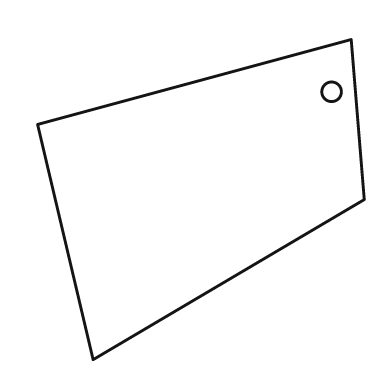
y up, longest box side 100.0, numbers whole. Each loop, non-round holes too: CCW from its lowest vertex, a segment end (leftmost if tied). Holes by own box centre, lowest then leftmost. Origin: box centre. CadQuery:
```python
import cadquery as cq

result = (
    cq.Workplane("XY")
    .moveTo(-33.0, -49.0)
    .lineTo(50.0, 0.0)
    .lineTo(46.0, 49.0)
    .lineTo(-50.0, 23.0)
    .close()
    .moveTo(40.0, 33.0)
    .circle(3.0)
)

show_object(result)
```